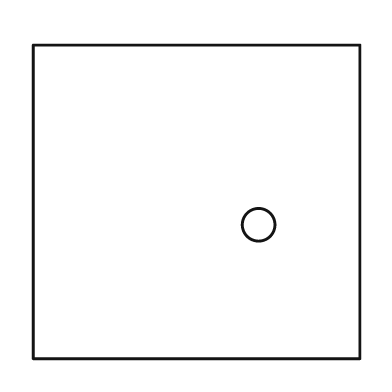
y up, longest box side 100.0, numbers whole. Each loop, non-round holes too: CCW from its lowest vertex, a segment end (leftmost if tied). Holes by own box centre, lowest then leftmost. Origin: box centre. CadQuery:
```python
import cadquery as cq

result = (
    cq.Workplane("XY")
    .moveTo(-50.0, -48.0)
    .lineTo(50.0, -48.0)
    .lineTo(50.0, 48.0)
    .lineTo(-50.0, 48.0)
    .close()
    .moveTo(19.0, -7.0)
    .circle(5.0)
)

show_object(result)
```